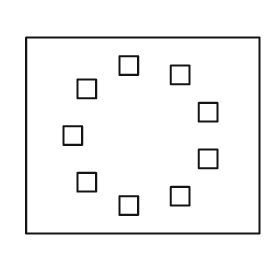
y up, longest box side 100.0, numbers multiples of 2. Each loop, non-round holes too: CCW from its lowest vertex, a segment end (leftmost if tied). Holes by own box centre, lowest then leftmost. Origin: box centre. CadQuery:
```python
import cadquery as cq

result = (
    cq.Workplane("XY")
    .moveTo(-50.0, -42.0)
    .lineTo(50.0, -42.0)
    .lineTo(50.0, 42.0)
    .lineTo(-50.0, 42.0)
    .close()
    .moveTo(-10.0, -34.0)
    .lineTo(-2.0, -34.0)
    .lineTo(-2.0, -26.0)
    .lineTo(-10.0, -26.0)
    .close()
    .moveTo(12.0, -30.0)
    .lineTo(20.0, -30.0)
    .lineTo(20.0, -22.0)
    .lineTo(12.0, -22.0)
    .close()
    .moveTo(-28.0, -24.0)
    .lineTo(-20.0, -24.0)
    .lineTo(-20.0, -16.0)
    .lineTo(-28.0, -16.0)
    .close()
    .moveTo(24.0, -14.0)
    .lineTo(32.0, -14.0)
    .lineTo(32.0, -6.0)
    .lineTo(24.0, -6.0)
    .close()
    .moveTo(-34.0, -4.0)
    .lineTo(-26.0, -4.0)
    .lineTo(-26.0, 4.0)
    .lineTo(-34.0, 4.0)
    .close()
    .moveTo(24.0, 6.0)
    .lineTo(32.0, 6.0)
    .lineTo(32.0, 14.0)
    .lineTo(24.0, 14.0)
    .close()
    .moveTo(-28.0, 16.0)
    .lineTo(-20.0, 16.0)
    .lineTo(-20.0, 24.0)
    .lineTo(-28.0, 24.0)
    .close()
    .moveTo(12.0, 22.0)
    .lineTo(20.0, 22.0)
    .lineTo(20.0, 30.0)
    .lineTo(12.0, 30.0)
    .close()
    .moveTo(-10.0, 26.0)
    .lineTo(-2.0, 26.0)
    .lineTo(-2.0, 34.0)
    .lineTo(-10.0, 34.0)
    .close()
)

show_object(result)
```